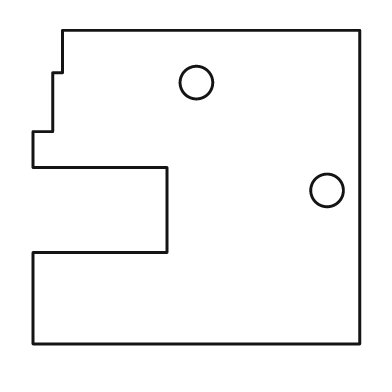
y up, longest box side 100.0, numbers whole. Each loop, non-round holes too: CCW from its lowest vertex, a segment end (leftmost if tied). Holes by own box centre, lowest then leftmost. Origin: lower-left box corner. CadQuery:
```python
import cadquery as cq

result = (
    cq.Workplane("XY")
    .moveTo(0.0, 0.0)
    .lineTo(100.0, 0.0)
    .lineTo(100.0, 96.0)
    .lineTo(9.0, 96.0)
    .lineTo(9.0, 83.0)
    .lineTo(6.0, 83.0)
    .lineTo(6.0, 65.0)
    .lineTo(0.0, 65.0)
    .lineTo(0.0, 54.0)
    .lineTo(41.0, 54.0)
    .lineTo(41.0, 28.0)
    .lineTo(0.0, 28.0)
    .close()
    .moveTo(90.0, 47.0)
    .circle(5.0)
    .moveTo(50.0, 80.0)
    .circle(5.0)
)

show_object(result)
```